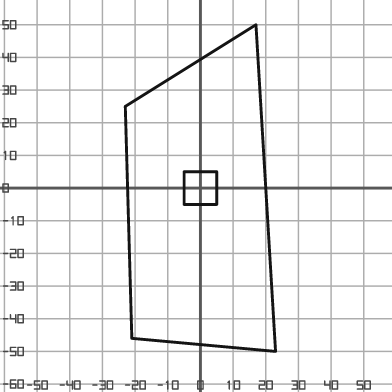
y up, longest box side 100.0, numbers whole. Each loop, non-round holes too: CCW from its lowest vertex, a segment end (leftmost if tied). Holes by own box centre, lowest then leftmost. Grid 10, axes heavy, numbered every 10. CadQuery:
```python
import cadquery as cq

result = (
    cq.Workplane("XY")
    .moveTo(23.0, -50.0)
    .lineTo(17.0, 50.0)
    .lineTo(-23.0, 25.0)
    .lineTo(-21.0, -46.0)
    .close()
    .moveTo(-5.0, -5.0)
    .lineTo(5.0, -5.0)
    .lineTo(5.0, 5.0)
    .lineTo(-5.0, 5.0)
    .close()
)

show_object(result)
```